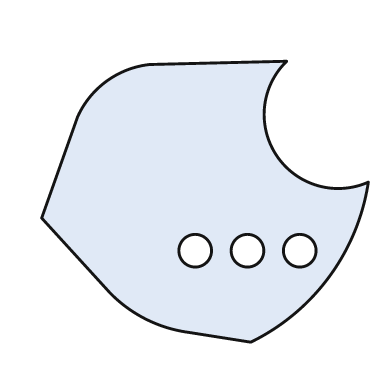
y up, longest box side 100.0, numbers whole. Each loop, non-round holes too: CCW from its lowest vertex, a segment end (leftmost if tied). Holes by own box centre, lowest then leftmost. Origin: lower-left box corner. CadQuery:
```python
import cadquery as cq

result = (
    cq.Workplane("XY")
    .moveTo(64.0, 0.0)
    .threePointArc((88.0, 20.0), (100.0, 49.0))
    .threePointArc((72.0, 57.0), (75.0, 86.0))
    .lineTo(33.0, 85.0)
    .threePointArc((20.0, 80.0), (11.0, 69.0))
    .lineTo(0.0, 38.0)
    .lineTo(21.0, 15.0)
    .threePointArc((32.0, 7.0), (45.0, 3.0))
    .close()
    .moveTo(47.0, 28.0)
    .circle(5.0)
    .moveTo(63.0, 28.0)
    .circle(5.0)
    .moveTo(79.0, 28.0)
    .circle(5.0)
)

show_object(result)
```